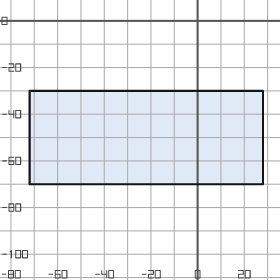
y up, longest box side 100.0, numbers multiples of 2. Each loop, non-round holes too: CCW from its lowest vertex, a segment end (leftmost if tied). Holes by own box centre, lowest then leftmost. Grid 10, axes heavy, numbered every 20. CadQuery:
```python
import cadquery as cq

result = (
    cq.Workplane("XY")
    .moveTo(-72.0, -70.0)
    .lineTo(28.0, -70.0)
    .lineTo(28.0, -30.0)
    .lineTo(-72.0, -30.0)
    .close()
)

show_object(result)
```